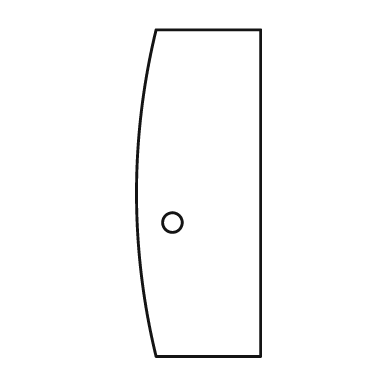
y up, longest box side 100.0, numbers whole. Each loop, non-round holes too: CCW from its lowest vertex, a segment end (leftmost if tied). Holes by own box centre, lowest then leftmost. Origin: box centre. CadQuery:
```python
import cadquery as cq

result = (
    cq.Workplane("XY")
    .moveTo(-13.0, -50.0)
    .lineTo(19.0, -50.0)
    .lineTo(19.0, 50.0)
    .lineTo(-13.0, 50.0)
    .threePointArc((-19.0, 0.0), (-13.0, -50.0))
    .close()
    .moveTo(-8.0, -9.0)
    .circle(3.0)
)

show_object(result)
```